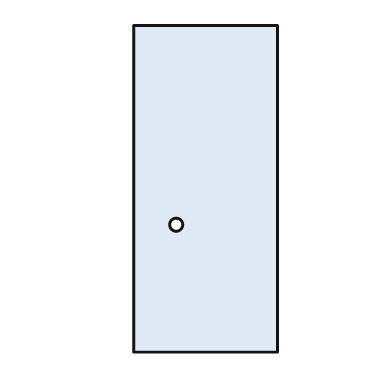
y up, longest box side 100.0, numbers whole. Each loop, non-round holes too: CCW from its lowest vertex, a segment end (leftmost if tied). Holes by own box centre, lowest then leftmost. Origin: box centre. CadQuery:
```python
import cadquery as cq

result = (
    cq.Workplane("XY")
    .moveTo(-22.0, -50.0)
    .lineTo(22.0, -50.0)
    .lineTo(22.0, 50.0)
    .lineTo(-22.0, 50.0)
    .close()
    .moveTo(-9.0, -11.0)
    .circle(2.0)
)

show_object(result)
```